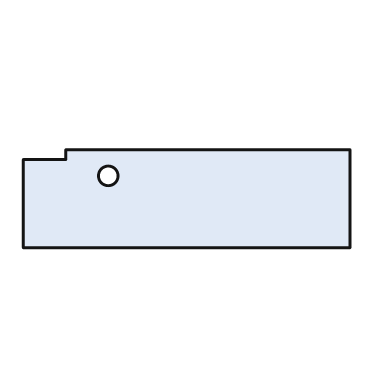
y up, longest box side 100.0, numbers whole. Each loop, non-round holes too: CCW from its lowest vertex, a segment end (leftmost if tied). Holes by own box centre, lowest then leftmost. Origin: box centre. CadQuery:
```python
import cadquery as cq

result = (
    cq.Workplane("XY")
    .moveTo(-50.0, -15.0)
    .lineTo(50.0, -15.0)
    .lineTo(50.0, 15.0)
    .lineTo(-37.0, 15.0)
    .lineTo(-37.0, 12.0)
    .lineTo(-50.0, 12.0)
    .close()
    .moveTo(-24.0, 7.0)
    .circle(3.0)
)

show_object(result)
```